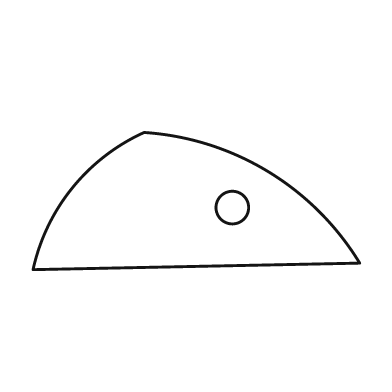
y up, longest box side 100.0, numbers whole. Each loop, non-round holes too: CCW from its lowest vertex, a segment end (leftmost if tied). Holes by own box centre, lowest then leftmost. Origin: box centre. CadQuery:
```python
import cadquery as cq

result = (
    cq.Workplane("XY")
    .moveTo(-50.0, -21.0)
    .lineTo(50.0, -19.0)
    .threePointArc((22.0, 9.0), (-16.0, 21.0))
    .threePointArc((-38.0, 4.0), (-50.0, -21.0))
    .close()
    .moveTo(11.0, -2.0)
    .circle(5.0)
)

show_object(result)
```